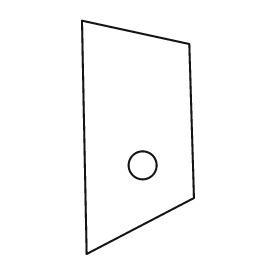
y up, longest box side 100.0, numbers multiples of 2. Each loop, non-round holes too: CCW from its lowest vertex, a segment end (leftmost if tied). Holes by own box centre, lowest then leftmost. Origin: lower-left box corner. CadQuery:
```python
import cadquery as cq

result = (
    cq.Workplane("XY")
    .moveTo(2.0, 0.0)
    .lineTo(48.0, 24.0)
    .lineTo(46.0, 90.0)
    .lineTo(0.0, 100.0)
    .close()
    .moveTo(26.0, 38.0)
    .circle(6.0)
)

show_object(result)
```